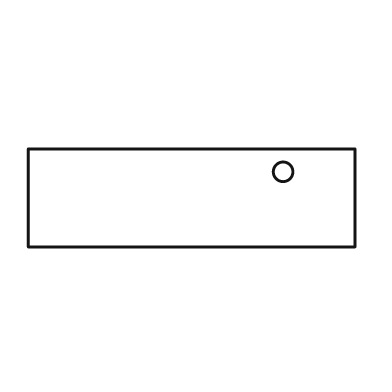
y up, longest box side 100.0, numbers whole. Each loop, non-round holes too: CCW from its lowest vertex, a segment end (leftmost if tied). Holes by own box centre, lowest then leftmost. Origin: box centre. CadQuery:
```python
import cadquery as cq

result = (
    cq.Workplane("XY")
    .moveTo(-50.0, -15.0)
    .lineTo(50.0, -15.0)
    .lineTo(50.0, 15.0)
    .lineTo(-50.0, 15.0)
    .close()
    .moveTo(28.0, 8.0)
    .circle(3.0)
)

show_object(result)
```